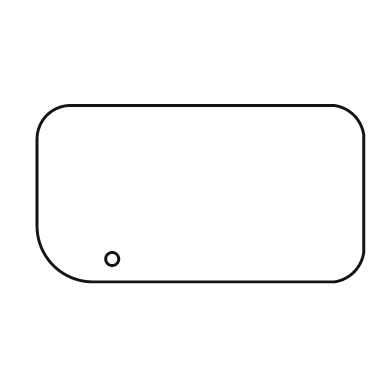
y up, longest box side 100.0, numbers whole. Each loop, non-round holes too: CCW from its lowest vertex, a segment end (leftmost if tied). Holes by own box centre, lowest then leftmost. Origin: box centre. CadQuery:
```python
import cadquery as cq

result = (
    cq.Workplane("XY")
    .moveTo(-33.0, -27.0)
    .lineTo(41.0, -27.0)
    .threePointArc((47.0, -24.0), (50.0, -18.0))
    .lineTo(50.0, 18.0)
    .threePointArc((47.0, 24.0), (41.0, 27.0))
    .lineTo(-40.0, 27.0)
    .threePointArc((-47.0, 24.0), (-50.0, 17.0))
    .lineTo(-50.0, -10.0)
    .threePointArc((-45.0, -22.0), (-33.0, -27.0))
    .close()
    .moveTo(-27.0, -20.0)
    .circle(2.0)
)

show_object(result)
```